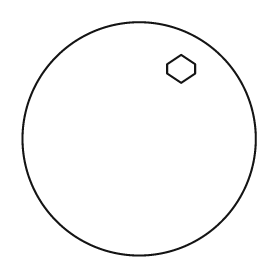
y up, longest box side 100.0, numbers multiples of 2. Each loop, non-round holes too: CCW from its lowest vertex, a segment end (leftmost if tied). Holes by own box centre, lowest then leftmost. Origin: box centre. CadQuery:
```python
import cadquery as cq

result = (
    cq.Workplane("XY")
    .moveTo(0.0, 0.0)
    .circle(50.0)
    .moveTo(18.0, 24.0)
    .lineTo(24.0, 28.0)
    .lineTo(24.0, 32.0)
    .lineTo(18.0, 36.0)
    .lineTo(12.0, 32.0)
    .lineTo(12.0, 28.0)
    .close()
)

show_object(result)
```